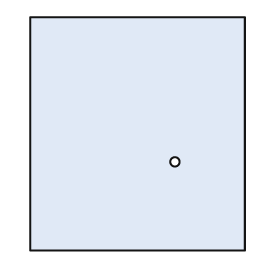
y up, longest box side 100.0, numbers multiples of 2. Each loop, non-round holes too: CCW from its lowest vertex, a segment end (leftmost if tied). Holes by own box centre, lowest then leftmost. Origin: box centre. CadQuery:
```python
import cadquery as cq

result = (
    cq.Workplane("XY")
    .moveTo(-46.0, -50.0)
    .lineTo(46.0, -50.0)
    .lineTo(46.0, 50.0)
    .lineTo(-46.0, 50.0)
    .close()
    .moveTo(16.0, -12.0)
    .circle(2.0)
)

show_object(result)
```